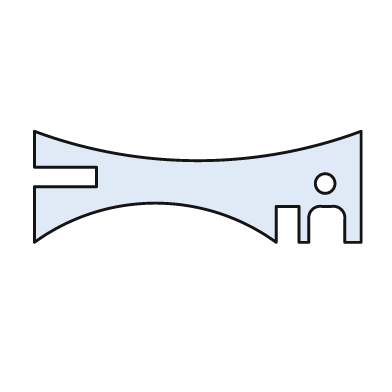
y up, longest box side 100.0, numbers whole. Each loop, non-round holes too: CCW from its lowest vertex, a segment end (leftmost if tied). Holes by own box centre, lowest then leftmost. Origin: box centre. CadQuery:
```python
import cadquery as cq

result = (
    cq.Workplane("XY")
    .moveTo(-50.0, -17.0)
    .threePointArc((-13.0, -5.0), (24.0, -17.0))
    .lineTo(24.0, -6.0)
    .lineTo(31.0, -6.0)
    .lineTo(31.0, -17.0)
    .lineTo(34.0, -17.0)
    .lineTo(34.0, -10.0)
    .threePointArc((35.0, -7.0), (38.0, -6.0))
    .lineTo(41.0, -6.0)
    .threePointArc((44.0, -7.0), (45.0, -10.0))
    .lineTo(45.0, -17.0)
    .lineTo(50.0, -17.0)
    .lineTo(50.0, 17.0)
    .threePointArc((0.0, 8.0), (-50.0, 17.0))
    .lineTo(-50.0, 6.0)
    .lineTo(-31.0, 6.0)
    .lineTo(-31.0, 0.0)
    .lineTo(-50.0, 0.0)
    .close()
    .moveTo(39.0, 1.0)
    .circle(3.0)
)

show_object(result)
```